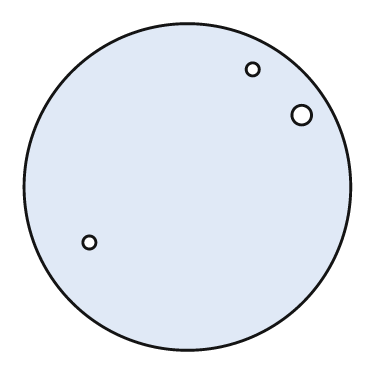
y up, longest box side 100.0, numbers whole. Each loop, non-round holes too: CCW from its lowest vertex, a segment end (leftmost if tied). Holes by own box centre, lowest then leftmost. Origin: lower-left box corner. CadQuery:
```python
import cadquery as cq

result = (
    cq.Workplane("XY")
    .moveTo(50.0, 50.0)
    .circle(50.0)
    .moveTo(20.0, 33.0)
    .circle(2.0)
    .moveTo(85.0, 72.0)
    .circle(3.0)
    .moveTo(70.0, 86.0)
    .circle(2.0)
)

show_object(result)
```